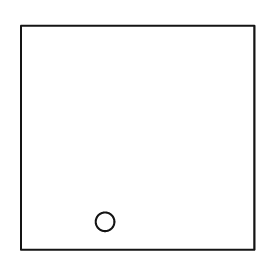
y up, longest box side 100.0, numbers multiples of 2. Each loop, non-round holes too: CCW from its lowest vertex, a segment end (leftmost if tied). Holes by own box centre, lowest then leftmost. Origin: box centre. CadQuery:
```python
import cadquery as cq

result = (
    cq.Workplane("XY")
    .moveTo(-50.0, -48.0)
    .lineTo(50.0, -48.0)
    .lineTo(50.0, 48.0)
    .lineTo(-50.0, 48.0)
    .close()
    .moveTo(-14.0, -36.0)
    .circle(4.0)
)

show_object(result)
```